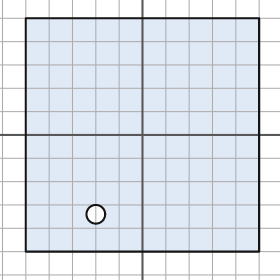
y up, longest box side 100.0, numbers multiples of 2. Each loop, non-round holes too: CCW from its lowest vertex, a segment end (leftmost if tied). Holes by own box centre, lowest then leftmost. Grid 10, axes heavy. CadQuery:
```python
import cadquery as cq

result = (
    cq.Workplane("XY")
    .moveTo(-50.0, -50.0)
    .lineTo(50.0, -50.0)
    .lineTo(50.0, 50.0)
    .lineTo(-50.0, 50.0)
    .close()
    .moveTo(-20.0, -34.0)
    .circle(4.0)
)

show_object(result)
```